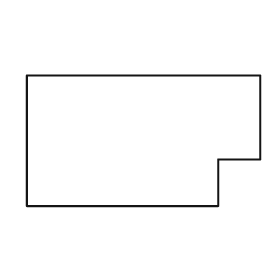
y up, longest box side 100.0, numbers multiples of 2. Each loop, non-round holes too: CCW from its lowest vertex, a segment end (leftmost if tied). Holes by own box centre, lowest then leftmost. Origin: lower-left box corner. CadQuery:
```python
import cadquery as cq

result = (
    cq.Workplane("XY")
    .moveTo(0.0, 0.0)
    .lineTo(82.0, 0.0)
    .lineTo(82.0, 20.0)
    .lineTo(100.0, 20.0)
    .lineTo(100.0, 56.0)
    .lineTo(0.0, 56.0)
    .close()
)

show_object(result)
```